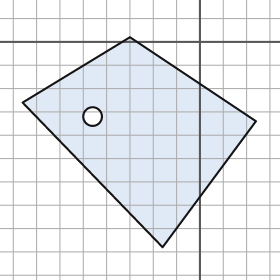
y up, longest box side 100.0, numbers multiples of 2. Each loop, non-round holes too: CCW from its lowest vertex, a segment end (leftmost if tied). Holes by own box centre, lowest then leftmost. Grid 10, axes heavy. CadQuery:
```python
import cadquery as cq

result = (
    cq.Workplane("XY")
    .moveTo(-16.0, -88.0)
    .lineTo(24.0, -34.0)
    .lineTo(-30.0, 2.0)
    .lineTo(-76.0, -26.0)
    .close()
    .moveTo(-46.0, -32.0)
    .circle(4.0)
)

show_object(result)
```